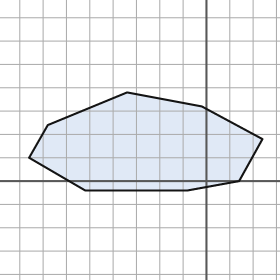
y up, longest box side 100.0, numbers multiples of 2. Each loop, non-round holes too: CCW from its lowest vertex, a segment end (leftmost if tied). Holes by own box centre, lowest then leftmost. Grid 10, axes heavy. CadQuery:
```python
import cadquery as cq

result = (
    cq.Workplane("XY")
    .moveTo(-52.0, -4.0)
    .lineTo(-8.0, -4.0)
    .lineTo(14.0, 0.0)
    .lineTo(24.0, 18.0)
    .lineTo(-2.0, 32.0)
    .lineTo(-34.0, 38.0)
    .lineTo(-68.0, 24.0)
    .lineTo(-76.0, 10.0)
    .close()
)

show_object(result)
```